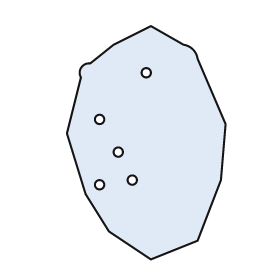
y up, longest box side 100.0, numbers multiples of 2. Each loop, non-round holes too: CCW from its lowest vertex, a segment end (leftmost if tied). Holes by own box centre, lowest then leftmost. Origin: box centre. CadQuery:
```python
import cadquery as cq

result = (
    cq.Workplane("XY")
    .moveTo(2.0, -50.0)
    .lineTo(22.0, -42.0)
    .lineTo(32.0, -16.0)
    .lineTo(34.0, 8.0)
    .lineTo(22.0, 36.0)
    .threePointArc((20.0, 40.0), (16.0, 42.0))
    .lineTo(2.0, 50.0)
    .lineTo(-14.0, 42.0)
    .lineTo(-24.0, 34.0)
    .threePointArc((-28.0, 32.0), (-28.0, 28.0))
    .lineTo(-34.0, 4.0)
    .lineTo(-26.0, -22.0)
    .lineTo(-16.0, -38.0)
    .close()
    .moveTo(-20.0, -18.0)
    .circle(2.0)
    .moveTo(-6.0, -16.0)
    .circle(2.0)
    .moveTo(-12.0, -4.0)
    .circle(2.0)
    .moveTo(-20.0, 10.0)
    .circle(2.0)
    .moveTo(0.0, 30.0)
    .circle(2.0)
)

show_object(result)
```